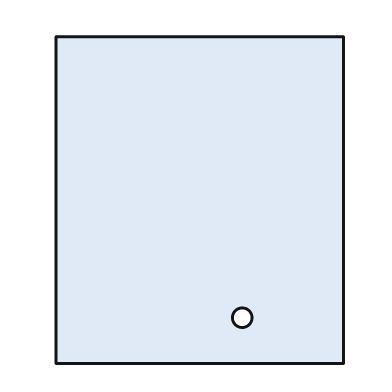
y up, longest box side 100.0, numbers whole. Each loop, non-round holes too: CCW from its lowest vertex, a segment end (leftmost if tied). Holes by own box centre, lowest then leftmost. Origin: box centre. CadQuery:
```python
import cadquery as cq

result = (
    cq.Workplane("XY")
    .moveTo(-44.0, -50.0)
    .lineTo(44.0, -50.0)
    .lineTo(44.0, 50.0)
    .lineTo(-44.0, 50.0)
    .close()
    .moveTo(13.0, -36.0)
    .circle(3.0)
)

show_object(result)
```